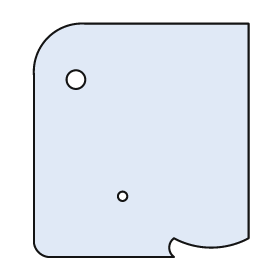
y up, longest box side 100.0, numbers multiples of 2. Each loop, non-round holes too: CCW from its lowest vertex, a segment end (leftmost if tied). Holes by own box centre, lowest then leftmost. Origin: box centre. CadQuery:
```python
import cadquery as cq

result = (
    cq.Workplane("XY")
    .moveTo(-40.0, -50.0)
    .lineTo(14.0, -50.0)
    .threePointArc((12.0, -46.0), (14.0, -42.0))
    .threePointArc((30.0, -46.0), (46.0, -42.0))
    .lineTo(46.0, 50.0)
    .lineTo(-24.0, 50.0)
    .threePointArc((-40.0, 44.0), (-46.0, 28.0))
    .lineTo(-46.0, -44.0)
    .threePointArc((-44.0, -48.0), (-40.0, -50.0))
    .close()
    .moveTo(-8.0, -24.0)
    .circle(2.0)
    .moveTo(-28.0, 26.0)
    .circle(4.0)
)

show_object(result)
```